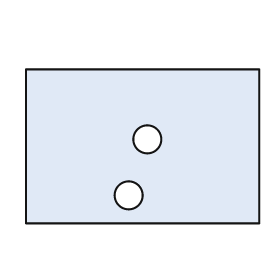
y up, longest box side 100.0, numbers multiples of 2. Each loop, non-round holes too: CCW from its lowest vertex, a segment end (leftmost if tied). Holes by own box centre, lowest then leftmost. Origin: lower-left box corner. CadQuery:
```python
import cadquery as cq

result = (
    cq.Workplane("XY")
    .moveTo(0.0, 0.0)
    .lineTo(100.0, 0.0)
    .lineTo(100.0, 66.0)
    .lineTo(0.0, 66.0)
    .close()
    .moveTo(44.0, 12.0)
    .circle(6.0)
    .moveTo(52.0, 36.0)
    .circle(6.0)
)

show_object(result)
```